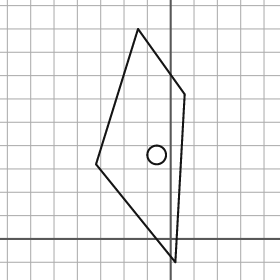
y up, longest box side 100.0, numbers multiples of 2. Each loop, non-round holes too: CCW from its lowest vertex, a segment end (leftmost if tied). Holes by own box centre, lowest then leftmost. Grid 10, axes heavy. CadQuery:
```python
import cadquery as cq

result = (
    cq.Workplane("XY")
    .moveTo(2.0, -10.0)
    .lineTo(6.0, 62.0)
    .lineTo(-14.0, 90.0)
    .lineTo(-32.0, 32.0)
    .close()
    .moveTo(-6.0, 36.0)
    .circle(4.0)
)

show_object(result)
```